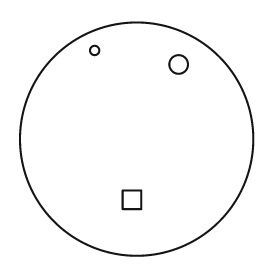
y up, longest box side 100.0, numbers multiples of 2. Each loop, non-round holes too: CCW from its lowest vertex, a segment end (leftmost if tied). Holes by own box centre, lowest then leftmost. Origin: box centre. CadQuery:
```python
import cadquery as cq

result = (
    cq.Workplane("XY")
    .moveTo(0.0, 0.0)
    .circle(50.0)
    .moveTo(-6.0, -30.0)
    .lineTo(2.0, -30.0)
    .lineTo(2.0, -22.0)
    .lineTo(-6.0, -22.0)
    .close()
    .moveTo(18.0, 32.0)
    .circle(4.0)
    .moveTo(-18.0, 38.0)
    .circle(2.0)
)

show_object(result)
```